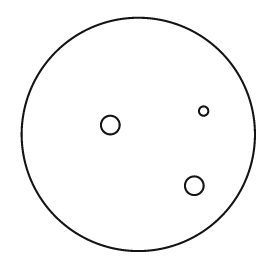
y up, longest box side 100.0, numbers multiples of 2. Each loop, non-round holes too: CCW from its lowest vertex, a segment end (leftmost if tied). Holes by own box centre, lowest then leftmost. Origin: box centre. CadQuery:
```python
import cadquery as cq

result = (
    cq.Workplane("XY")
    .moveTo(0.0, 0.0)
    .circle(50.0)
    .moveTo(24.0, -22.0)
    .circle(4.0)
    .moveTo(-12.0, 4.0)
    .circle(4.0)
    .moveTo(28.0, 10.0)
    .circle(2.0)
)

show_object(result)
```